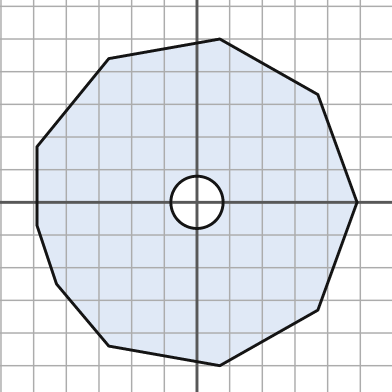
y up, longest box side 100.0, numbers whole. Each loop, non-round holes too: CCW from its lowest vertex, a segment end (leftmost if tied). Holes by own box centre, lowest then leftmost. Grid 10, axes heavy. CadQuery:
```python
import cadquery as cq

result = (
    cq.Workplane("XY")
    .moveTo(7.0, -50.0)
    .lineTo(37.0, -33.0)
    .lineTo(49.0, 0.0)
    .lineTo(37.0, 33.0)
    .lineTo(7.0, 50.0)
    .lineTo(-27.0, 44.0)
    .lineTo(-49.0, 17.0)
    .lineTo(-49.0, -7.0)
    .lineTo(-43.0, -25.0)
    .lineTo(-27.0, -44.0)
    .close()
    .moveTo(0.0, 0.0)
    .circle(8.0)
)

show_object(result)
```